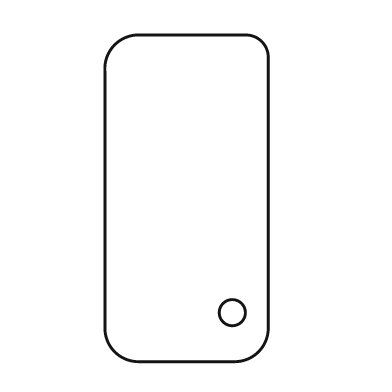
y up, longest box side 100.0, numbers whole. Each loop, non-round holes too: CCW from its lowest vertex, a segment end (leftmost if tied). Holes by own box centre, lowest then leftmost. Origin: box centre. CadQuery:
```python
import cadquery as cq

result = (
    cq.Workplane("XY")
    .moveTo(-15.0, -50.0)
    .lineTo(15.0, -50.0)
    .threePointArc((22.0, -47.0), (25.0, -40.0))
    .lineTo(25.0, 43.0)
    .threePointArc((23.0, 48.0), (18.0, 50.0))
    .lineTo(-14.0, 50.0)
    .threePointArc((-22.0, 47.0), (-25.0, 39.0))
    .lineTo(-25.0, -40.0)
    .threePointArc((-22.0, -47.0), (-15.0, -50.0))
    .close()
    .moveTo(14.0, -35.0)
    .circle(4.0)
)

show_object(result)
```